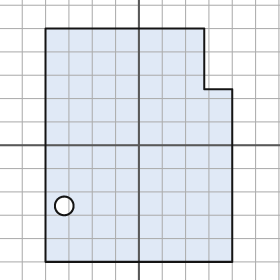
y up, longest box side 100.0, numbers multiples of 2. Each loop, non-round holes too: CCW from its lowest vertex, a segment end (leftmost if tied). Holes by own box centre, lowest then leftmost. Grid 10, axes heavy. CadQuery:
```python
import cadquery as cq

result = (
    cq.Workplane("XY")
    .moveTo(-40.0, -50.0)
    .lineTo(40.0, -50.0)
    .lineTo(40.0, 24.0)
    .lineTo(28.0, 24.0)
    .lineTo(28.0, 50.0)
    .lineTo(-40.0, 50.0)
    .close()
    .moveTo(-32.0, -26.0)
    .circle(4.0)
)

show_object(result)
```